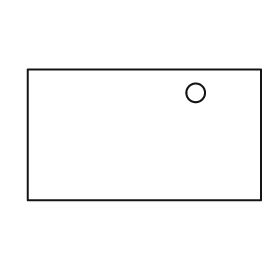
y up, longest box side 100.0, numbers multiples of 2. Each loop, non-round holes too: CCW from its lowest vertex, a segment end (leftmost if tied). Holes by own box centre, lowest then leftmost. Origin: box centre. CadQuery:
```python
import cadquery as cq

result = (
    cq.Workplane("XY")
    .moveTo(-50.0, -28.0)
    .lineTo(50.0, -28.0)
    .lineTo(50.0, 28.0)
    .lineTo(-50.0, 28.0)
    .close()
    .moveTo(22.0, 18.0)
    .circle(4.0)
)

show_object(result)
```